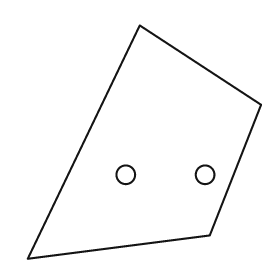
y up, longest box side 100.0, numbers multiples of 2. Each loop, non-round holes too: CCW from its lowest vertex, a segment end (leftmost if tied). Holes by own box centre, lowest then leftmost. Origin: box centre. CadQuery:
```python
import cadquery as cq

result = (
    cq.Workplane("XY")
    .moveTo(-50.0, -50.0)
    .lineTo(28.0, -40.0)
    .lineTo(50.0, 16.0)
    .lineTo(-2.0, 50.0)
    .close()
    .moveTo(-8.0, -14.0)
    .circle(4.0)
    .moveTo(26.0, -14.0)
    .circle(4.0)
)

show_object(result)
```